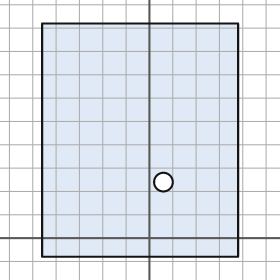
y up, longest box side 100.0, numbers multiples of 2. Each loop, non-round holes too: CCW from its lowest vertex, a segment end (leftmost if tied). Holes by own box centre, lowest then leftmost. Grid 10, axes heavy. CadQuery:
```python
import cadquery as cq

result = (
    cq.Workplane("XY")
    .moveTo(-46.0, -8.0)
    .lineTo(38.0, -8.0)
    .lineTo(38.0, 92.0)
    .lineTo(-46.0, 92.0)
    .close()
    .moveTo(6.0, 24.0)
    .circle(4.0)
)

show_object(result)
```